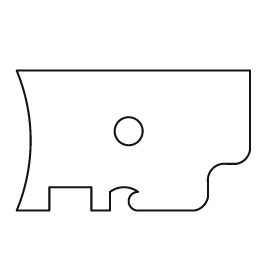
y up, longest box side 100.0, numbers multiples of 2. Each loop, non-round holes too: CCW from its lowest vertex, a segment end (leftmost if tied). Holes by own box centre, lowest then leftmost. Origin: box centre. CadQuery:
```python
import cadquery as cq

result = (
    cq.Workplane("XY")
    .moveTo(-50.0, -30.0)
    .lineTo(-36.0, -30.0)
    .lineTo(-36.0, -20.0)
    .lineTo(-18.0, -20.0)
    .lineTo(-18.0, -30.0)
    .lineTo(-10.0, -30.0)
    .lineTo(-10.0, -22.0)
    .threePointArc((-4.0, -20.0), (2.0, -22.0))
    .threePointArc((-2.0, -26.0), (2.0, -30.0))
    .lineTo(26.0, -30.0)
    .threePointArc((30.0, -28.0), (32.0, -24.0))
    .lineTo(32.0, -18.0)
    .threePointArc((34.0, -12.0), (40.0, -10.0))
    .lineTo(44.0, -10.0)
    .threePointArc((48.0, -8.0), (50.0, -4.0))
    .lineTo(50.0, 30.0)
    .lineTo(-50.0, 30.0)
    .threePointArc((-44.0, 0.0), (-50.0, -30.0))
    .close()
    .moveTo(-2.0, 4.0)
    .circle(6.0)
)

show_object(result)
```